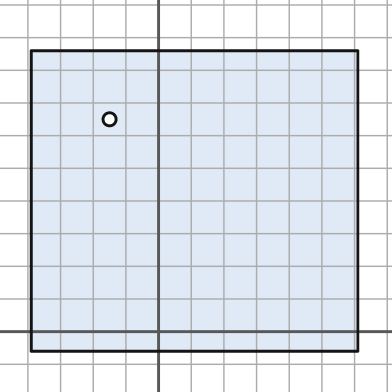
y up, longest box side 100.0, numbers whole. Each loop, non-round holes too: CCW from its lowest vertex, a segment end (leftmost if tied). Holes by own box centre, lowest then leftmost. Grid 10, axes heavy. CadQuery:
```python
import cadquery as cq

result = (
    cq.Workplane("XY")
    .moveTo(-39.0, -6.0)
    .lineTo(61.0, -6.0)
    .lineTo(61.0, 86.0)
    .lineTo(-39.0, 86.0)
    .close()
    .moveTo(-15.0, 65.0)
    .circle(2.0)
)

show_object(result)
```